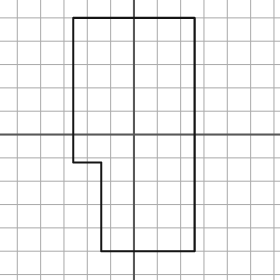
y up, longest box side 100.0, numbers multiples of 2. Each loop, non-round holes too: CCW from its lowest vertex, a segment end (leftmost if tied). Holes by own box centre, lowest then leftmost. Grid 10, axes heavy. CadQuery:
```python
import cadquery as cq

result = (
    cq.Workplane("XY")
    .moveTo(-14.0, -50.0)
    .lineTo(26.0, -50.0)
    .lineTo(26.0, 50.0)
    .lineTo(-26.0, 50.0)
    .lineTo(-26.0, -12.0)
    .lineTo(-14.0, -12.0)
    .close()
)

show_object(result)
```